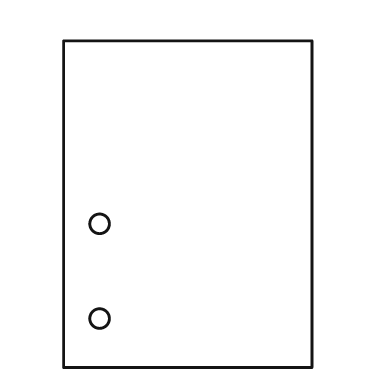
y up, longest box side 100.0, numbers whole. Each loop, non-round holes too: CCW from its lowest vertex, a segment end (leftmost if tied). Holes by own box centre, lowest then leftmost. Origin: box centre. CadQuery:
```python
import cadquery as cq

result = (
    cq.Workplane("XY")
    .moveTo(-38.0, -50.0)
    .lineTo(38.0, -50.0)
    .lineTo(38.0, 50.0)
    .lineTo(-38.0, 50.0)
    .close()
    .moveTo(-27.0, -35.0)
    .circle(3.0)
    .moveTo(-27.0, -6.0)
    .circle(3.0)
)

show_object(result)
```